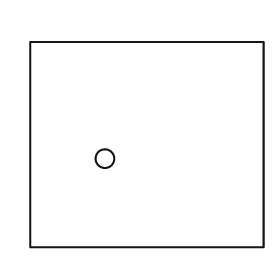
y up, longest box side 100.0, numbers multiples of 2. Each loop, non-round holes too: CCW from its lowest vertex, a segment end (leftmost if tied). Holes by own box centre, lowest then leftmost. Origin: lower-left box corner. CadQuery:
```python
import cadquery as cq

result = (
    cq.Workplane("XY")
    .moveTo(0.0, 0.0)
    .lineTo(100.0, 0.0)
    .lineTo(100.0, 88.0)
    .lineTo(0.0, 88.0)
    .close()
    .moveTo(32.0, 38.0)
    .circle(4.0)
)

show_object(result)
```